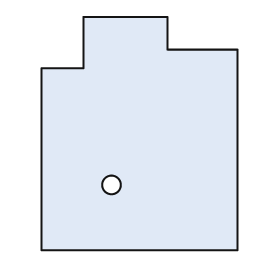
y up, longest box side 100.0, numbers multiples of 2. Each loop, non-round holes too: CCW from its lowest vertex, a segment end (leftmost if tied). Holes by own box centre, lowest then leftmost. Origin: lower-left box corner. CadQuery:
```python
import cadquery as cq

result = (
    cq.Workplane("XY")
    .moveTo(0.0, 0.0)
    .lineTo(84.0, 0.0)
    .lineTo(84.0, 86.0)
    .lineTo(54.0, 86.0)
    .lineTo(54.0, 100.0)
    .lineTo(18.0, 100.0)
    .lineTo(18.0, 78.0)
    .lineTo(0.0, 78.0)
    .close()
    .moveTo(30.0, 28.0)
    .circle(4.0)
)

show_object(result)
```